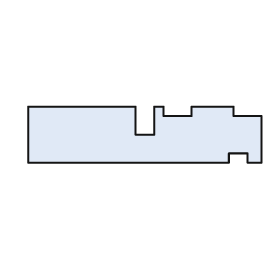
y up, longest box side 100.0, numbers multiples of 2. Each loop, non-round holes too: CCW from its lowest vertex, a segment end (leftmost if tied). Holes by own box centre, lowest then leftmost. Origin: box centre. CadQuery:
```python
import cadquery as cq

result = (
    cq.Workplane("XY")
    .moveTo(-50.0, -12.0)
    .lineTo(36.0, -12.0)
    .lineTo(36.0, -8.0)
    .lineTo(44.0, -8.0)
    .lineTo(44.0, -12.0)
    .lineTo(50.0, -12.0)
    .lineTo(50.0, 8.0)
    .lineTo(38.0, 8.0)
    .lineTo(38.0, 12.0)
    .lineTo(20.0, 12.0)
    .lineTo(20.0, 8.0)
    .lineTo(8.0, 8.0)
    .lineTo(8.0, 12.0)
    .lineTo(4.0, 12.0)
    .lineTo(4.0, 0.0)
    .lineTo(-4.0, 0.0)
    .lineTo(-4.0, 12.0)
    .lineTo(-50.0, 12.0)
    .close()
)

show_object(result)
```